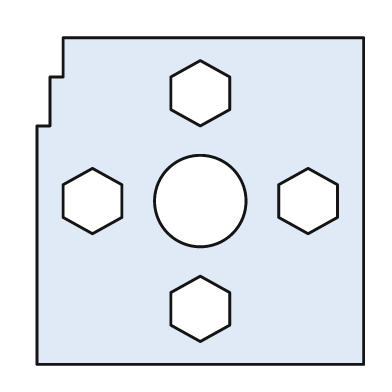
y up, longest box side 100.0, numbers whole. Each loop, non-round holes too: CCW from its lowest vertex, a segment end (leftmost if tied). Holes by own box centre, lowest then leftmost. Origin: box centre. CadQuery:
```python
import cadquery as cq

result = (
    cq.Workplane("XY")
    .moveTo(-50.0, -50.0)
    .lineTo(50.0, -50.0)
    .lineTo(50.0, 50.0)
    .lineTo(-42.0, 50.0)
    .lineTo(-42.0, 38.0)
    .lineTo(-46.0, 38.0)
    .lineTo(-46.0, 23.0)
    .lineTo(-50.0, 23.0)
    .close()
    .moveTo(0.0, -43.0)
    .lineTo(9.0, -38.0)
    .lineTo(9.0, -28.0)
    .lineTo(0.0, -23.0)
    .lineTo(-9.0, -28.0)
    .lineTo(-9.0, -38.0)
    .close()
    .moveTo(-33.0, -10.0)
    .lineTo(-24.0, -5.0)
    .lineTo(-24.0, 5.0)
    .lineTo(-33.0, 10.0)
    .lineTo(-42.0, 5.0)
    .lineTo(-42.0, -5.0)
    .close()
    .moveTo(0.0, 0.0)
    .circle(14.0)
    .moveTo(33.0, -10.0)
    .lineTo(42.0, -5.0)
    .lineTo(42.0, 5.0)
    .lineTo(33.0, 10.0)
    .lineTo(24.0, 5.0)
    .lineTo(24.0, -5.0)
    .close()
    .moveTo(0.0, 23.0)
    .lineTo(9.0, 28.0)
    .lineTo(9.0, 38.0)
    .lineTo(0.0, 43.0)
    .lineTo(-9.0, 38.0)
    .lineTo(-9.0, 28.0)
    .close()
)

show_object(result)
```